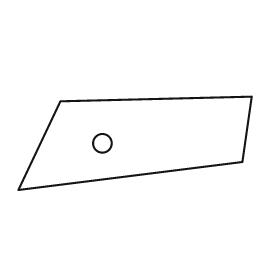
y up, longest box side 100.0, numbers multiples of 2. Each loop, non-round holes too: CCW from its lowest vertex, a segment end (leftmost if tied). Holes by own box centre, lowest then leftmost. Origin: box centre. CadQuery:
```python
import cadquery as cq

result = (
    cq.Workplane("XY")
    .moveTo(-50.0, -20.0)
    .lineTo(46.0, -8.0)
    .lineTo(50.0, 20.0)
    .lineTo(-32.0, 18.0)
    .close()
    .moveTo(-14.0, 0.0)
    .circle(4.0)
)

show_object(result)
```